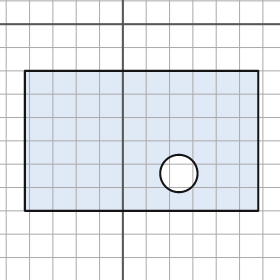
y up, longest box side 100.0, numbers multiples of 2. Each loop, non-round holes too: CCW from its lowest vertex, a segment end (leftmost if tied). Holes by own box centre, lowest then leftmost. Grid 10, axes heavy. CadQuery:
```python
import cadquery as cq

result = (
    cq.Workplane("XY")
    .moveTo(-42.0, -80.0)
    .lineTo(58.0, -80.0)
    .lineTo(58.0, -20.0)
    .lineTo(-42.0, -20.0)
    .close()
    .moveTo(24.0, -64.0)
    .circle(8.0)
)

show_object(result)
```